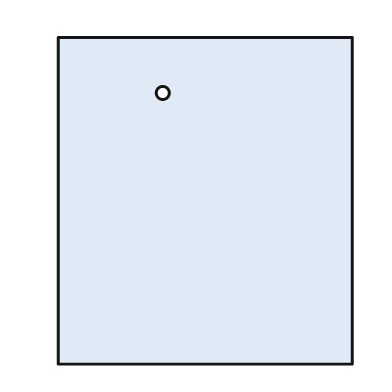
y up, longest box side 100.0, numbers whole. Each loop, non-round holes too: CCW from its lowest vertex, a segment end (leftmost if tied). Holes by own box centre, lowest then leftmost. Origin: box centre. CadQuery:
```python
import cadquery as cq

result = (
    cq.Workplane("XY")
    .moveTo(-45.0, -50.0)
    .lineTo(45.0, -50.0)
    .lineTo(45.0, 50.0)
    .lineTo(-45.0, 50.0)
    .close()
    .moveTo(-13.0, 33.0)
    .circle(2.0)
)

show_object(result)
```